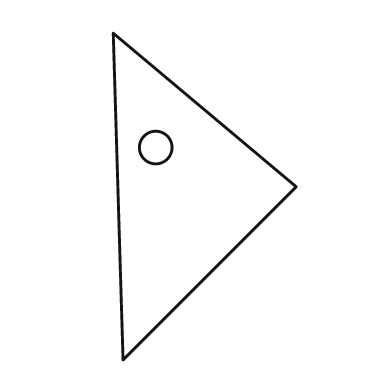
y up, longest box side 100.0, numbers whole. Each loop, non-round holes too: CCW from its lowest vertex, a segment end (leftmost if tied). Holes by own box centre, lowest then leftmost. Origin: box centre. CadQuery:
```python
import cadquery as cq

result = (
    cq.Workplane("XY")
    .moveTo(-25.0, -50.0)
    .lineTo(28.0, 3.0)
    .lineTo(-28.0, 50.0)
    .close()
    .moveTo(-15.0, 15.0)
    .circle(5.0)
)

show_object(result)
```